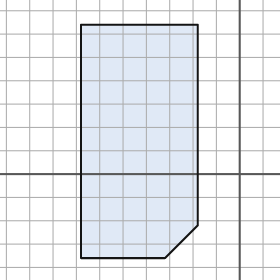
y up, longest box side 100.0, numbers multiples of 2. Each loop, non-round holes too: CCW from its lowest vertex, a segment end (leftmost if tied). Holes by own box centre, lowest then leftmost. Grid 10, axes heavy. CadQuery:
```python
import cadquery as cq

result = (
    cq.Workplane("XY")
    .moveTo(-68.0, -36.0)
    .lineTo(-32.0, -36.0)
    .lineTo(-18.0, -22.0)
    .lineTo(-18.0, 64.0)
    .lineTo(-68.0, 64.0)
    .close()
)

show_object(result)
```